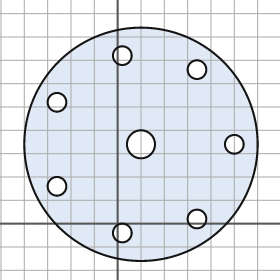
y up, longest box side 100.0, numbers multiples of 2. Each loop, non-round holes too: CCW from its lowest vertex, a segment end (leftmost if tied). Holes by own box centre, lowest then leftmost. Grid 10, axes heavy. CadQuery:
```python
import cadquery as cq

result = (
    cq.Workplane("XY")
    .moveTo(10.0, 34.0)
    .circle(50.0)
    .moveTo(2.0, -4.0)
    .circle(4.0)
    .moveTo(34.0, 2.0)
    .circle(4.0)
    .moveTo(-26.0, 16.0)
    .circle(4.0)
    .moveTo(10.0, 34.0)
    .circle(6.0)
    .moveTo(50.0, 34.0)
    .circle(4.0)
    .moveTo(-26.0, 52.0)
    .circle(4.0)
    .moveTo(34.0, 66.0)
    .circle(4.0)
    .moveTo(2.0, 72.0)
    .circle(4.0)
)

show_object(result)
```